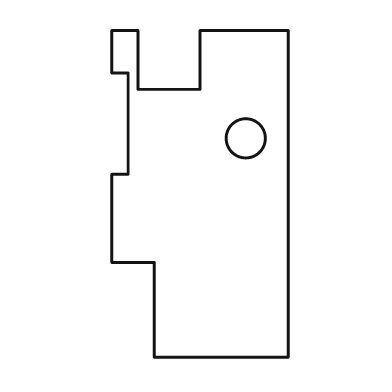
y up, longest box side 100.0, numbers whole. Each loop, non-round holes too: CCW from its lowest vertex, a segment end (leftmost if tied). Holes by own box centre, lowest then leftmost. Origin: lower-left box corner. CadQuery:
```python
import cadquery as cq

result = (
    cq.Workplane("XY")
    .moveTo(13.0, 0.0)
    .lineTo(54.0, 0.0)
    .lineTo(54.0, 100.0)
    .lineTo(27.0, 100.0)
    .lineTo(27.0, 82.0)
    .lineTo(8.0, 82.0)
    .lineTo(8.0, 100.0)
    .lineTo(0.0, 100.0)
    .lineTo(0.0, 87.0)
    .lineTo(5.0, 87.0)
    .lineTo(5.0, 56.0)
    .lineTo(0.0, 56.0)
    .lineTo(0.0, 29.0)
    .lineTo(13.0, 29.0)
    .close()
    .moveTo(41.0, 67.0)
    .circle(6.0)
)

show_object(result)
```